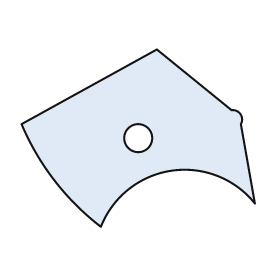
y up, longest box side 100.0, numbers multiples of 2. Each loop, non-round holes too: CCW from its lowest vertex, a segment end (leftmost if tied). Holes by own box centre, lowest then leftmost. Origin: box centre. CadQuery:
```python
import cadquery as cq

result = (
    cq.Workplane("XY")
    .moveTo(-16.0, -38.0)
    .threePointArc((14.0, -14.0), (50.0, -28.0))
    .lineTo(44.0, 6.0)
    .threePointArc((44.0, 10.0), (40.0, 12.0))
    .lineTo(8.0, 38.0)
    .lineTo(-50.0, 6.0)
    .threePointArc((-36.0, -18.0), (-16.0, -38.0))
    .close()
    .moveTo(0.0, 0.0)
    .circle(6.0)
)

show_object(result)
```